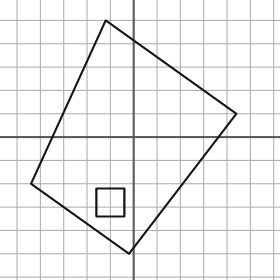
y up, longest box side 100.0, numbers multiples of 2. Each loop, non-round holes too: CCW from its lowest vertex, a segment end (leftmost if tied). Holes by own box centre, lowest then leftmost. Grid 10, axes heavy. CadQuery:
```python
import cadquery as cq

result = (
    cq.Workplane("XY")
    .moveTo(-2.0, -50.0)
    .lineTo(44.0, 10.0)
    .lineTo(-12.0, 50.0)
    .lineTo(-44.0, -20.0)
    .close()
    .moveTo(-16.0, -34.0)
    .lineTo(-4.0, -34.0)
    .lineTo(-4.0, -22.0)
    .lineTo(-16.0, -22.0)
    .close()
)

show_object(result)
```